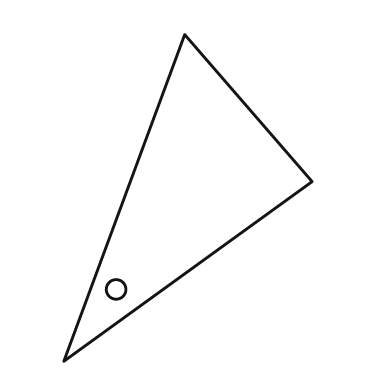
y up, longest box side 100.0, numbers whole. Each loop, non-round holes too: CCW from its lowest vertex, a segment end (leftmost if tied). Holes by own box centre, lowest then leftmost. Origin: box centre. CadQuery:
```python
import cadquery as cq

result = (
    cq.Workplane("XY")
    .moveTo(-38.0, -50.0)
    .lineTo(38.0, 5.0)
    .lineTo(-1.0, 50.0)
    .close()
    .moveTo(-22.0, -28.0)
    .circle(3.0)
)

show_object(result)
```